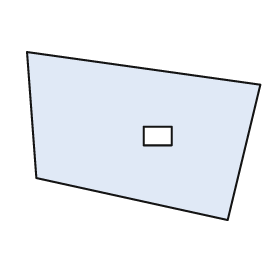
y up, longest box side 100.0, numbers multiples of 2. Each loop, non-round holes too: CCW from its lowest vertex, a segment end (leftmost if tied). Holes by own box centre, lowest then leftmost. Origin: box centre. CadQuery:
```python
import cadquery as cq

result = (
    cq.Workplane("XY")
    .moveTo(36.0, -36.0)
    .lineTo(50.0, 22.0)
    .lineTo(-50.0, 36.0)
    .lineTo(-46.0, -18.0)
    .close()
    .moveTo(0.0, -4.0)
    .lineTo(12.0, -4.0)
    .lineTo(12.0, 4.0)
    .lineTo(0.0, 4.0)
    .close()
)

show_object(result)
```